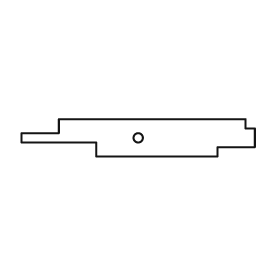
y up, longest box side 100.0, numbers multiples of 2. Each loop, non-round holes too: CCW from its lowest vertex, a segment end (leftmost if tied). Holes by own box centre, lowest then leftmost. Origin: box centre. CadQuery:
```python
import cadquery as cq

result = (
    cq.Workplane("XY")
    .moveTo(-18.0, -8.0)
    .lineTo(34.0, -8.0)
    .lineTo(34.0, -4.0)
    .lineTo(50.0, -4.0)
    .lineTo(50.0, 4.0)
    .lineTo(46.0, 4.0)
    .lineTo(46.0, 8.0)
    .lineTo(-34.0, 8.0)
    .lineTo(-34.0, 2.0)
    .lineTo(-50.0, 2.0)
    .lineTo(-50.0, -2.0)
    .lineTo(-18.0, -2.0)
    .close()
    .moveTo(0.0, 0.0)
    .circle(2.0)
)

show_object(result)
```